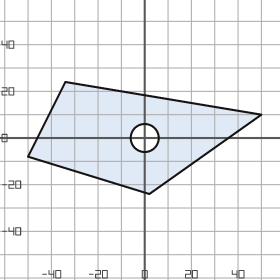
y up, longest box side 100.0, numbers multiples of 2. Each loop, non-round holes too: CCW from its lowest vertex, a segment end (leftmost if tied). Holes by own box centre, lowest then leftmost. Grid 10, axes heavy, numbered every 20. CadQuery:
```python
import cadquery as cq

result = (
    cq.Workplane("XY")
    .moveTo(2.0, -24.0)
    .lineTo(50.0, 10.0)
    .lineTo(-34.0, 24.0)
    .lineTo(-50.0, -8.0)
    .close()
    .moveTo(0.0, 0.0)
    .circle(6.0)
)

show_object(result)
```